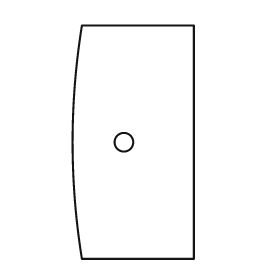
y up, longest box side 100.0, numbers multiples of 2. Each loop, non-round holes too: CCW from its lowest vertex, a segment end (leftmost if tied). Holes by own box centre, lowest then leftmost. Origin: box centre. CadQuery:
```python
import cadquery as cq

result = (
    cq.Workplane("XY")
    .moveTo(-22.0, -50.0)
    .lineTo(26.0, -50.0)
    .lineTo(26.0, 50.0)
    .lineTo(-22.0, 50.0)
    .threePointArc((-26.0, 0.0), (-22.0, -50.0))
    .close()
    .moveTo(-4.0, 0.0)
    .circle(4.0)
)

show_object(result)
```